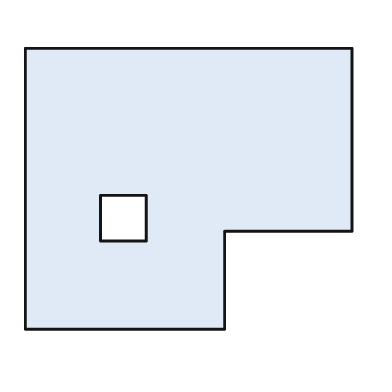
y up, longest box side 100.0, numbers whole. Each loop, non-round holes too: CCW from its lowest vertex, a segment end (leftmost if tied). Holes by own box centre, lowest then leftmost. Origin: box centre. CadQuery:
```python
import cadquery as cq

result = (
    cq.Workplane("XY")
    .moveTo(-50.0, -43.0)
    .lineTo(11.0, -43.0)
    .lineTo(11.0, -13.0)
    .lineTo(50.0, -13.0)
    .lineTo(50.0, 43.0)
    .lineTo(-50.0, 43.0)
    .close()
    .moveTo(-27.0, -16.0)
    .lineTo(-13.0, -16.0)
    .lineTo(-13.0, -2.0)
    .lineTo(-27.0, -2.0)
    .close()
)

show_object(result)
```